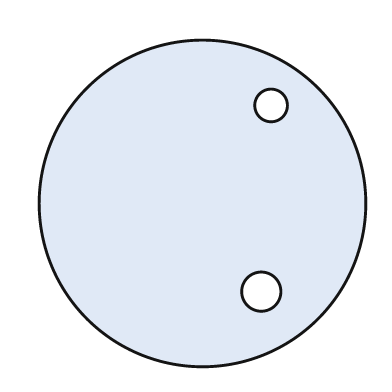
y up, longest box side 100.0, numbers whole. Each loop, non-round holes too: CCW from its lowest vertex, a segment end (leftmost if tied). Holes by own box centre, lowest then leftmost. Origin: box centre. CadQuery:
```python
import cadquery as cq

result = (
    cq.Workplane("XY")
    .moveTo(0.0, 0.0)
    .circle(50.0)
    .moveTo(18.0, -27.0)
    .circle(6.0)
    .moveTo(21.0, 30.0)
    .circle(5.0)
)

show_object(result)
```